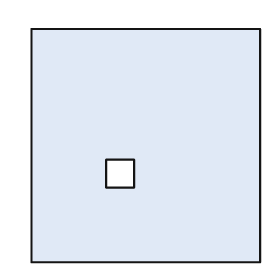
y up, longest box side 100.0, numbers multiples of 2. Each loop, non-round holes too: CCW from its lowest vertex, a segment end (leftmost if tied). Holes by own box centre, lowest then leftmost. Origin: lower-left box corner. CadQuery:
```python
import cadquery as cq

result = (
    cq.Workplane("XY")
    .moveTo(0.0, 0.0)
    .lineTo(98.0, 0.0)
    .lineTo(98.0, 100.0)
    .lineTo(0.0, 100.0)
    .close()
    .moveTo(32.0, 32.0)
    .lineTo(44.0, 32.0)
    .lineTo(44.0, 44.0)
    .lineTo(32.0, 44.0)
    .close()
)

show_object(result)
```